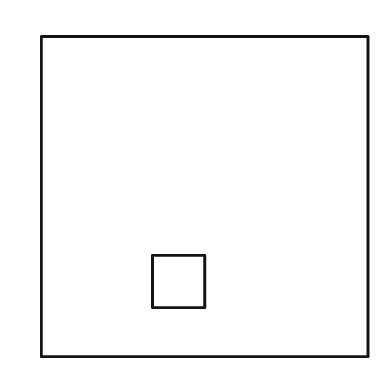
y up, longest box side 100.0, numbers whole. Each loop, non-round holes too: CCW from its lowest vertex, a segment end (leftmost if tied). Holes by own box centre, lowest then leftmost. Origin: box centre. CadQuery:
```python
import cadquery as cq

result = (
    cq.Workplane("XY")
    .moveTo(-50.0, -49.0)
    .lineTo(50.0, -49.0)
    .lineTo(50.0, 49.0)
    .lineTo(-50.0, 49.0)
    .close()
    .moveTo(-16.0, -34.0)
    .lineTo(0.0, -34.0)
    .lineTo(0.0, -18.0)
    .lineTo(-16.0, -18.0)
    .close()
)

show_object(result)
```